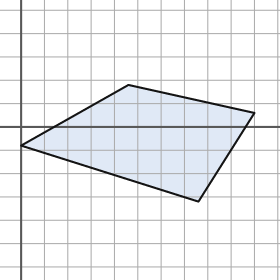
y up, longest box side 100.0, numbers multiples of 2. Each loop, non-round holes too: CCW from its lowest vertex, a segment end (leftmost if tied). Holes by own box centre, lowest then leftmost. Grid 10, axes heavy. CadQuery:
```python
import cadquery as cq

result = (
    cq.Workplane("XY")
    .moveTo(76.0, -32.0)
    .lineTo(100.0, 6.0)
    .lineTo(46.0, 18.0)
    .lineTo(0.0, -8.0)
    .close()
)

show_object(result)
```